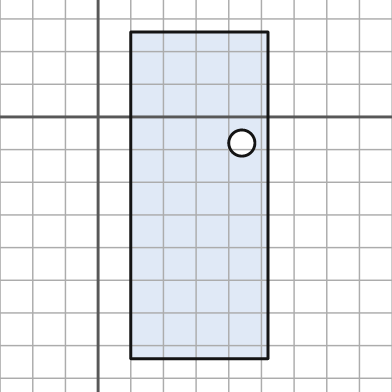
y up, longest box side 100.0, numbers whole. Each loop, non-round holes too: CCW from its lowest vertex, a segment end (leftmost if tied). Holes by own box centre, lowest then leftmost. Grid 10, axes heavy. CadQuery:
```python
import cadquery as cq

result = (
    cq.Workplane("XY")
    .moveTo(10.0, -74.0)
    .lineTo(52.0, -74.0)
    .lineTo(52.0, 26.0)
    .lineTo(10.0, 26.0)
    .close()
    .moveTo(44.0, -8.0)
    .circle(4.0)
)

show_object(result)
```